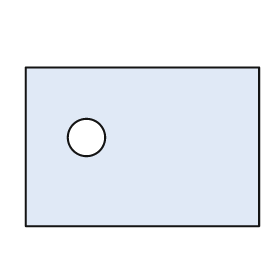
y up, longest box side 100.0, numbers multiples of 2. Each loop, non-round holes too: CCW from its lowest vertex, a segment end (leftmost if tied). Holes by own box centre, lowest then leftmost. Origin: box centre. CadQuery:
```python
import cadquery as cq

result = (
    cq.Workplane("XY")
    .moveTo(-50.0, -34.0)
    .lineTo(50.0, -34.0)
    .lineTo(50.0, 34.0)
    .lineTo(-50.0, 34.0)
    .close()
    .moveTo(-24.0, 4.0)
    .circle(8.0)
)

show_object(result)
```